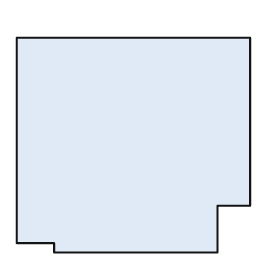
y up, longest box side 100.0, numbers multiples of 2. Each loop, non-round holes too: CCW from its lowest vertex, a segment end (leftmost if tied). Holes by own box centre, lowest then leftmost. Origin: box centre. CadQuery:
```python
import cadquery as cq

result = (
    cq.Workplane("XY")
    .moveTo(-34.0, -46.0)
    .lineTo(36.0, -46.0)
    .lineTo(36.0, -26.0)
    .lineTo(50.0, -26.0)
    .lineTo(50.0, 46.0)
    .lineTo(-50.0, 46.0)
    .lineTo(-50.0, -42.0)
    .lineTo(-34.0, -42.0)
    .close()
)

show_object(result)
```